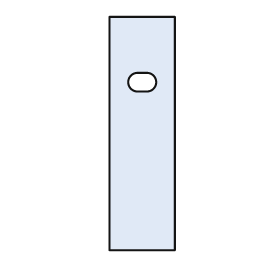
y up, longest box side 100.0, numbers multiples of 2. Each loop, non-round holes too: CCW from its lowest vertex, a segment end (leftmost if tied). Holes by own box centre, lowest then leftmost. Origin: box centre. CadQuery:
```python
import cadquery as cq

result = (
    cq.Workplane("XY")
    .moveTo(-14.0, -50.0)
    .lineTo(14.0, -50.0)
    .lineTo(14.0, 50.0)
    .lineTo(-14.0, 50.0)
    .close()
    .moveTo(-2.0, 18.0)
    .lineTo(2.0, 18.0)
    .threePointArc((6.0, 22.0), (2.0, 26.0))
    .lineTo(-2.0, 26.0)
    .threePointArc((-6.0, 22.0), (-2.0, 18.0))
    .close()
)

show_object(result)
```